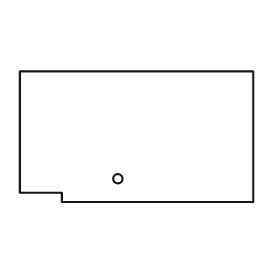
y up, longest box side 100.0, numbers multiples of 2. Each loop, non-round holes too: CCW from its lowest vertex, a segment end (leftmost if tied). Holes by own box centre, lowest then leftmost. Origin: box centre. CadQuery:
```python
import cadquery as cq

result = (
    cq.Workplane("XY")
    .moveTo(-32.0, -28.0)
    .lineTo(50.0, -28.0)
    .lineTo(50.0, 28.0)
    .lineTo(-50.0, 28.0)
    .lineTo(-50.0, -24.0)
    .lineTo(-32.0, -24.0)
    .close()
    .moveTo(-8.0, -18.0)
    .circle(2.0)
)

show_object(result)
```